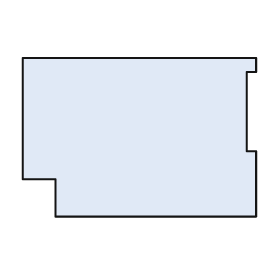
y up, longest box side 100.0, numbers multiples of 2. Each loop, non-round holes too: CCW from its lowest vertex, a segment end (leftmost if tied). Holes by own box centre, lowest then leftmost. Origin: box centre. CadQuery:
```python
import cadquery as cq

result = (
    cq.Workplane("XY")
    .moveTo(-36.0, -34.0)
    .lineTo(50.0, -34.0)
    .lineTo(50.0, -6.0)
    .lineTo(46.0, -6.0)
    .lineTo(46.0, 28.0)
    .lineTo(50.0, 28.0)
    .lineTo(50.0, 34.0)
    .lineTo(-50.0, 34.0)
    .lineTo(-50.0, -18.0)
    .lineTo(-36.0, -18.0)
    .close()
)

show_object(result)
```